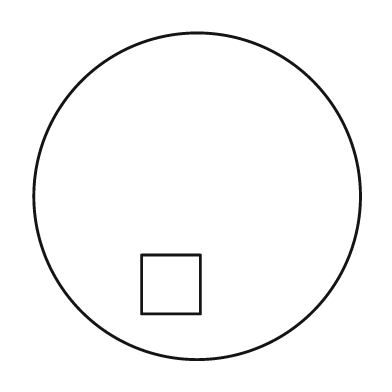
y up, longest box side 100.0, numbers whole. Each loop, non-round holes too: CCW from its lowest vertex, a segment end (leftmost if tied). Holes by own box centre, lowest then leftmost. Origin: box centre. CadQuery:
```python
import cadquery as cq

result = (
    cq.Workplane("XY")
    .moveTo(0.0, 0.0)
    .circle(50.0)
    .moveTo(-17.0, -36.0)
    .lineTo(1.0, -36.0)
    .lineTo(1.0, -18.0)
    .lineTo(-17.0, -18.0)
    .close()
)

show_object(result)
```